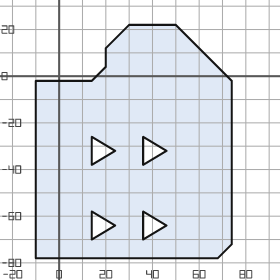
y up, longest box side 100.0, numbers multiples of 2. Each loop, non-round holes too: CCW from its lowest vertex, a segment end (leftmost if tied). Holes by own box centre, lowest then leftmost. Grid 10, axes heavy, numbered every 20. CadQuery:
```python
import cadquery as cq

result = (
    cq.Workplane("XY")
    .moveTo(-10.0, -78.0)
    .lineTo(68.0, -78.0)
    .lineTo(74.0, -72.0)
    .lineTo(74.0, -2.0)
    .lineTo(50.0, 22.0)
    .lineTo(30.0, 22.0)
    .lineTo(20.0, 12.0)
    .lineTo(20.0, 4.0)
    .lineTo(14.0, -2.0)
    .lineTo(-10.0, -2.0)
    .close()
    .moveTo(14.0, -70.0)
    .lineTo(24.0, -64.0)
    .lineTo(14.0, -58.0)
    .close()
    .moveTo(36.0, -70.0)
    .lineTo(46.0, -64.0)
    .lineTo(36.0, -58.0)
    .close()
    .moveTo(14.0, -38.0)
    .lineTo(24.0, -32.0)
    .lineTo(14.0, -26.0)
    .close()
    .moveTo(36.0, -38.0)
    .lineTo(46.0, -32.0)
    .lineTo(36.0, -26.0)
    .close()
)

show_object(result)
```